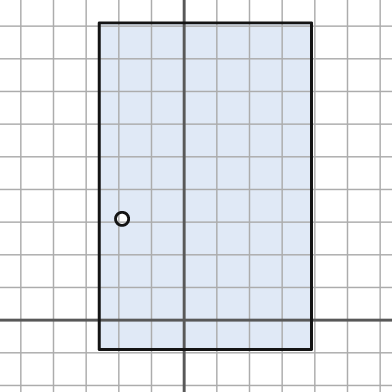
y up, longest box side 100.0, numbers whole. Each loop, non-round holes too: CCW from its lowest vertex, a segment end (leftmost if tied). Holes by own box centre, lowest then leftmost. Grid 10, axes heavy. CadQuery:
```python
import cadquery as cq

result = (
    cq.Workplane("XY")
    .moveTo(-26.0, -9.0)
    .lineTo(39.0, -9.0)
    .lineTo(39.0, 91.0)
    .lineTo(-26.0, 91.0)
    .close()
    .moveTo(-19.0, 31.0)
    .circle(2.0)
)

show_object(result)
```